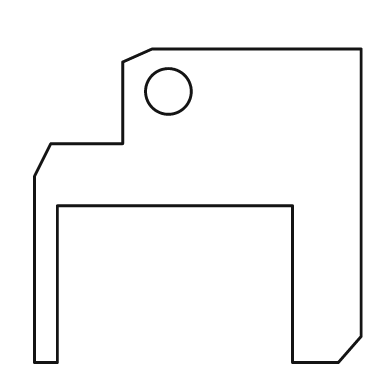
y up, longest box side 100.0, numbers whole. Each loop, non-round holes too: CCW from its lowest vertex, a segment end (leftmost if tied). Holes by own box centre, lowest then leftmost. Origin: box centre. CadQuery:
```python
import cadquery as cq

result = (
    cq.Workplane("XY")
    .moveTo(-50.0, -48.0)
    .lineTo(-43.0, -48.0)
    .lineTo(-43.0, 0.0)
    .lineTo(29.0, 0.0)
    .lineTo(29.0, -48.0)
    .lineTo(43.0, -48.0)
    .lineTo(50.0, -40.0)
    .lineTo(50.0, 48.0)
    .lineTo(-14.0, 48.0)
    .lineTo(-23.0, 44.0)
    .lineTo(-23.0, 19.0)
    .lineTo(-45.0, 19.0)
    .lineTo(-50.0, 9.0)
    .close()
    .moveTo(-9.0, 35.0)
    .circle(7.0)
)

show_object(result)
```